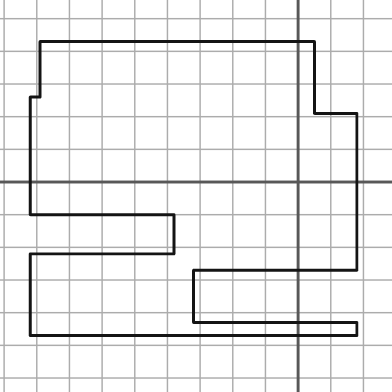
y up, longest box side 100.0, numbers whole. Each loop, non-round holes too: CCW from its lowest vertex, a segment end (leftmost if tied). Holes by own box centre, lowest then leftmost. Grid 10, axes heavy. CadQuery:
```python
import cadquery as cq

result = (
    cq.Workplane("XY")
    .moveTo(-82.0, -47.0)
    .lineTo(18.0, -47.0)
    .lineTo(18.0, -43.0)
    .lineTo(-32.0, -43.0)
    .lineTo(-32.0, -27.0)
    .lineTo(18.0, -27.0)
    .lineTo(18.0, 21.0)
    .lineTo(5.0, 21.0)
    .lineTo(5.0, 43.0)
    .lineTo(-79.0, 43.0)
    .lineTo(-79.0, 26.0)
    .lineTo(-82.0, 26.0)
    .lineTo(-82.0, -10.0)
    .lineTo(-38.0, -10.0)
    .lineTo(-38.0, -22.0)
    .lineTo(-82.0, -22.0)
    .close()
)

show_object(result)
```